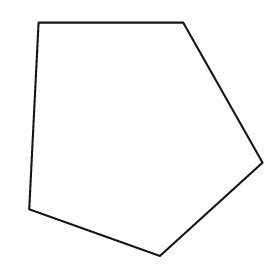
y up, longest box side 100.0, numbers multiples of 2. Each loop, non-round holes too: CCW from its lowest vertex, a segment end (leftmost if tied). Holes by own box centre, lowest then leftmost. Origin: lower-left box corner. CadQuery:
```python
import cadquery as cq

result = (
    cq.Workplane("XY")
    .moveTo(56.0, 0.0)
    .lineTo(100.0, 40.0)
    .lineTo(66.0, 100.0)
    .lineTo(4.0, 100.0)
    .lineTo(0.0, 20.0)
    .close()
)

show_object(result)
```